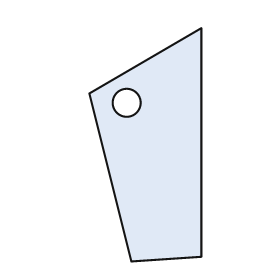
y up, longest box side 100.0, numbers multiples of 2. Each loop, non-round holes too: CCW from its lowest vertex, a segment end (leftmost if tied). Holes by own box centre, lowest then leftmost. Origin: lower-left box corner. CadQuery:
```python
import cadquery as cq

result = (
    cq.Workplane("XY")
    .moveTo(18.0, 0.0)
    .lineTo(48.0, 2.0)
    .lineTo(48.0, 100.0)
    .lineTo(0.0, 72.0)
    .close()
    .moveTo(16.0, 68.0)
    .circle(6.0)
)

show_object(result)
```